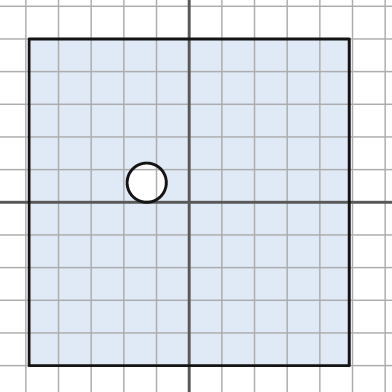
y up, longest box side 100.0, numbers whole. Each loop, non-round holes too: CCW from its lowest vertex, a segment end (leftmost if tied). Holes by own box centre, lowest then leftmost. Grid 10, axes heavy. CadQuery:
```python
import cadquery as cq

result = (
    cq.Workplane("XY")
    .moveTo(-49.0, -50.0)
    .lineTo(49.0, -50.0)
    .lineTo(49.0, 50.0)
    .lineTo(-49.0, 50.0)
    .close()
    .moveTo(-13.0, 6.0)
    .circle(6.0)
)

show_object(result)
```